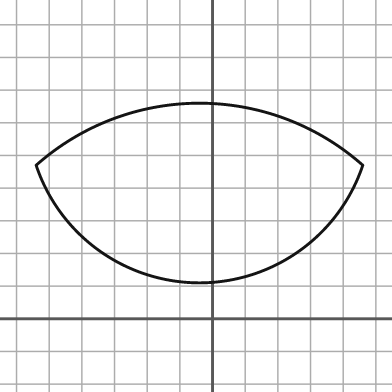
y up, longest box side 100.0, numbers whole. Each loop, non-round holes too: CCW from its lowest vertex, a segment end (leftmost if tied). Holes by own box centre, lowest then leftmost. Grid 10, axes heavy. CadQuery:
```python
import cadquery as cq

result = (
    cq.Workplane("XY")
    .moveTo(-54.0, 47.0)
    .threePointArc((-4.0, 11.0), (46.0, 47.0))
    .threePointArc((-4.0, 66.0), (-54.0, 47.0))
    .close()
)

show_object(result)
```